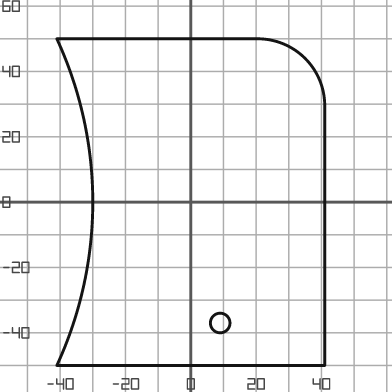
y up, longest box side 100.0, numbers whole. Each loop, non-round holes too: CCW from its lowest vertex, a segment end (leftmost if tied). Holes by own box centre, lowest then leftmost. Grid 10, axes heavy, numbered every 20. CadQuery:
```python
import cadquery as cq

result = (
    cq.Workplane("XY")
    .moveTo(-41.0, -50.0)
    .lineTo(41.0, -50.0)
    .lineTo(41.0, 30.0)
    .threePointArc((35.0, 44.0), (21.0, 50.0))
    .lineTo(-41.0, 50.0)
    .threePointArc((-30.0, 0.0), (-41.0, -50.0))
    .close()
    .moveTo(9.0, -37.0)
    .circle(3.0)
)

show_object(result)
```